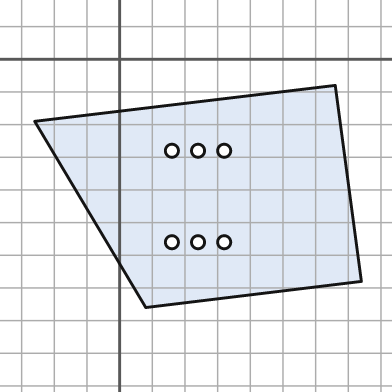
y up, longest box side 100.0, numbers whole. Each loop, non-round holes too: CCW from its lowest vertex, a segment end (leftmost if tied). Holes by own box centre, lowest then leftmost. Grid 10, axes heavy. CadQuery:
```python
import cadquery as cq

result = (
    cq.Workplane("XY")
    .moveTo(8.0, -76.0)
    .lineTo(74.0, -68.0)
    .lineTo(66.0, -8.0)
    .lineTo(-26.0, -19.0)
    .close()
    .moveTo(16.0, -56.0)
    .circle(2.0)
    .moveTo(24.0, -56.0)
    .circle(2.0)
    .moveTo(32.0, -56.0)
    .circle(2.0)
    .moveTo(16.0, -28.0)
    .circle(2.0)
    .moveTo(24.0, -28.0)
    .circle(2.0)
    .moveTo(32.0, -28.0)
    .circle(2.0)
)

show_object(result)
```